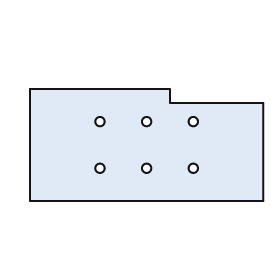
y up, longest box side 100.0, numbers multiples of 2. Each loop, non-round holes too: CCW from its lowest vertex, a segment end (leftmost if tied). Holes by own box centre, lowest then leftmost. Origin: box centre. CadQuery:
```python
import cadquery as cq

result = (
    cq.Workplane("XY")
    .moveTo(-50.0, -24.0)
    .lineTo(50.0, -24.0)
    .lineTo(50.0, 18.0)
    .lineTo(10.0, 18.0)
    .lineTo(10.0, 24.0)
    .lineTo(-50.0, 24.0)
    .close()
    .moveTo(-20.0, -10.0)
    .circle(2.0)
    .moveTo(0.0, -10.0)
    .circle(2.0)
    .moveTo(20.0, -10.0)
    .circle(2.0)
    .moveTo(-20.0, 10.0)
    .circle(2.0)
    .moveTo(0.0, 10.0)
    .circle(2.0)
    .moveTo(20.0, 10.0)
    .circle(2.0)
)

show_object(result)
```